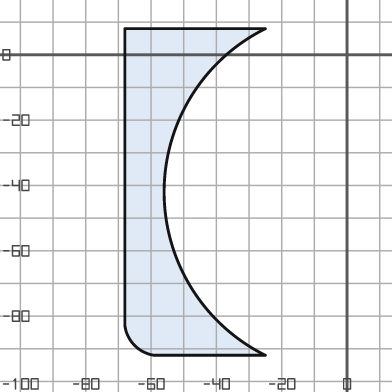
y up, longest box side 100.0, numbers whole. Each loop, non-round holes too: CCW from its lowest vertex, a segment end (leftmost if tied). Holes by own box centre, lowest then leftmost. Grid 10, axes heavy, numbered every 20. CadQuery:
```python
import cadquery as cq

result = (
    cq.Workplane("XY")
    .moveTo(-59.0, -92.0)
    .lineTo(-25.0, -92.0)
    .threePointArc((-56.0, -42.0), (-25.0, 8.0))
    .lineTo(-68.0, 8.0)
    .lineTo(-68.0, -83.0)
    .threePointArc((-65.0, -89.0), (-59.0, -92.0))
    .close()
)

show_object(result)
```